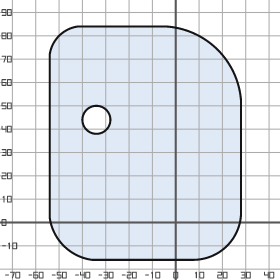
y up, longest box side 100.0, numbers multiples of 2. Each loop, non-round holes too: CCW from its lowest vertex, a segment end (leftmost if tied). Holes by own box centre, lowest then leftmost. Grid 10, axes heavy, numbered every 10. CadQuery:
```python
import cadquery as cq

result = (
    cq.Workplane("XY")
    .moveTo(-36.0, -16.0)
    .lineTo(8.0, -16.0)
    .threePointArc((22.0, -10.0), (28.0, 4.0))
    .lineTo(28.0, 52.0)
    .threePointArc((18.0, 74.0), (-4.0, 84.0))
    .lineTo(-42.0, 84.0)
    .threePointArc((-50.0, 80.0), (-54.0, 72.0))
    .lineTo(-54.0, 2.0)
    .threePointArc((-48.0, -10.0), (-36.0, -16.0))
    .close()
    .moveTo(-34.0, 44.0)
    .circle(6.0)
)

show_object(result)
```